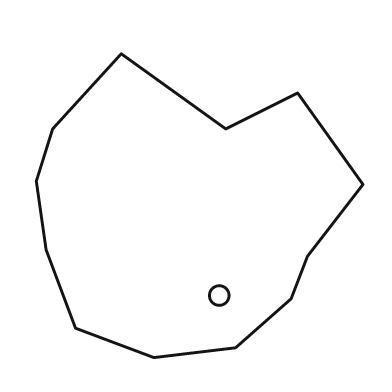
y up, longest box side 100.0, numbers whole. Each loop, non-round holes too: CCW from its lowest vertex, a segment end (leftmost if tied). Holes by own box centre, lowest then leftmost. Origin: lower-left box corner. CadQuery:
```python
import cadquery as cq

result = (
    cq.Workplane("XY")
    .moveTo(36.0, 0.0)
    .lineTo(61.0, 3.0)
    .lineTo(78.0, 18.0)
    .lineTo(83.0, 31.0)
    .lineTo(100.0, 53.0)
    .lineTo(80.0, 81.0)
    .lineTo(58.0, 70.0)
    .lineTo(26.0, 93.0)
    .lineTo(5.0, 70.0)
    .lineTo(0.0, 54.0)
    .lineTo(3.0, 33.0)
    .lineTo(12.0, 9.0)
    .close()
    .moveTo(56.0, 19.0)
    .circle(3.0)
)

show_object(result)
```